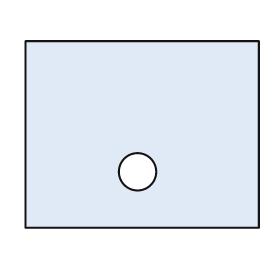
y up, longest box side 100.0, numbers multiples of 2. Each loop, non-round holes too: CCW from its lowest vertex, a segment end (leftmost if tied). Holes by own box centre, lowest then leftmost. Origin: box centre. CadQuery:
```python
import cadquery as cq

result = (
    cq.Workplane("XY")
    .moveTo(-50.0, -40.0)
    .lineTo(50.0, -40.0)
    .lineTo(50.0, 40.0)
    .lineTo(-50.0, 40.0)
    .close()
    .moveTo(-2.0, -16.0)
    .circle(8.0)
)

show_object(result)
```